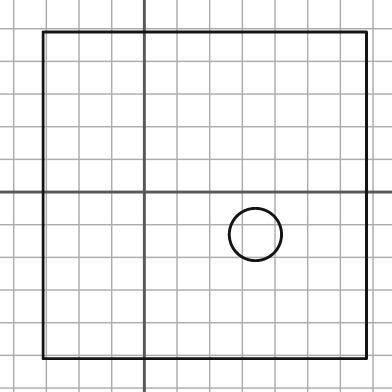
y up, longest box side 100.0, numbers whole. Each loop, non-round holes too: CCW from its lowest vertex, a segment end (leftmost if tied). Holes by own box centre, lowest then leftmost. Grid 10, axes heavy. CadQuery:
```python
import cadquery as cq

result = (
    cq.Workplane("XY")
    .moveTo(-31.0, -51.0)
    .lineTo(68.0, -51.0)
    .lineTo(68.0, 49.0)
    .lineTo(-31.0, 49.0)
    .close()
    .moveTo(34.0, -13.0)
    .circle(8.0)
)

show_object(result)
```